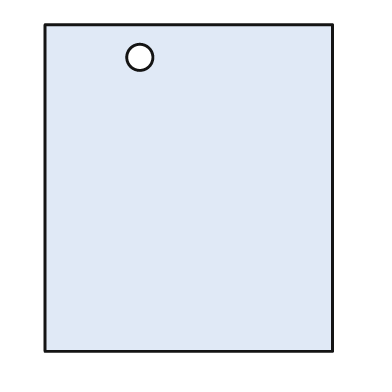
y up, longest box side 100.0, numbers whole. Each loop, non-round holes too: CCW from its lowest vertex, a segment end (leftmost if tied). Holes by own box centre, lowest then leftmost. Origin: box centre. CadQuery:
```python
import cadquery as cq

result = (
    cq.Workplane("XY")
    .moveTo(-44.0, -50.0)
    .lineTo(44.0, -50.0)
    .lineTo(44.0, 50.0)
    .lineTo(-44.0, 50.0)
    .close()
    .moveTo(-15.0, 40.0)
    .circle(4.0)
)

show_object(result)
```